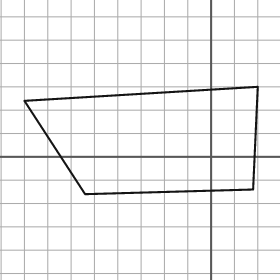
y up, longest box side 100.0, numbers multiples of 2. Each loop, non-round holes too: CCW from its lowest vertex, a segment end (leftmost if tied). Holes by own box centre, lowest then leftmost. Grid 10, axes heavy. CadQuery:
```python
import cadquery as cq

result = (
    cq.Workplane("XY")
    .moveTo(-54.0, -16.0)
    .lineTo(18.0, -14.0)
    .lineTo(20.0, 30.0)
    .lineTo(-80.0, 24.0)
    .close()
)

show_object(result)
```